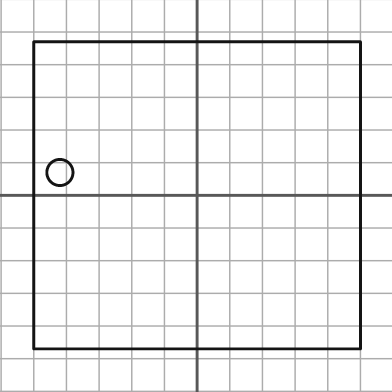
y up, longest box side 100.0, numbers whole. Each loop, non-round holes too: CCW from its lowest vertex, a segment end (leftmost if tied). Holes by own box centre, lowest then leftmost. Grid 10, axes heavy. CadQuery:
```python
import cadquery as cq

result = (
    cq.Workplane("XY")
    .moveTo(-50.0, -47.0)
    .lineTo(50.0, -47.0)
    .lineTo(50.0, 47.0)
    .lineTo(-50.0, 47.0)
    .close()
    .moveTo(-42.0, 7.0)
    .circle(4.0)
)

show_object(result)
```